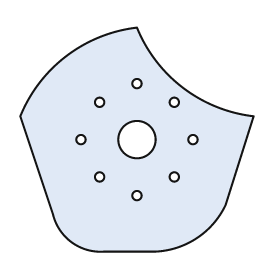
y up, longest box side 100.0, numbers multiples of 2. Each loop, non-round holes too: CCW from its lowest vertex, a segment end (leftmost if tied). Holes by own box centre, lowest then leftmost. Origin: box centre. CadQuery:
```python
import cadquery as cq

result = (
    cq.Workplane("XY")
    .moveTo(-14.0, -48.0)
    .lineTo(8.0, -48.0)
    .threePointArc((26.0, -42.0), (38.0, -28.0))
    .lineTo(50.0, 10.0)
    .threePointArc((20.0, 22.0), (0.0, 48.0))
    .threePointArc((-30.0, 36.0), (-50.0, 10.0))
    .lineTo(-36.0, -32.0)
    .threePointArc((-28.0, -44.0), (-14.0, -48.0))
    .close()
    .moveTo(0.0, -24.0)
    .circle(2.0)
    .moveTo(-16.0, -16.0)
    .circle(2.0)
    .moveTo(16.0, -16.0)
    .circle(2.0)
    .moveTo(-24.0, 0.0)
    .circle(2.0)
    .moveTo(0.0, 0.0)
    .circle(8.0)
    .moveTo(24.0, 0.0)
    .circle(2.0)
    .moveTo(-16.0, 16.0)
    .circle(2.0)
    .moveTo(16.0, 16.0)
    .circle(2.0)
    .moveTo(0.0, 24.0)
    .circle(2.0)
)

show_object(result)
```